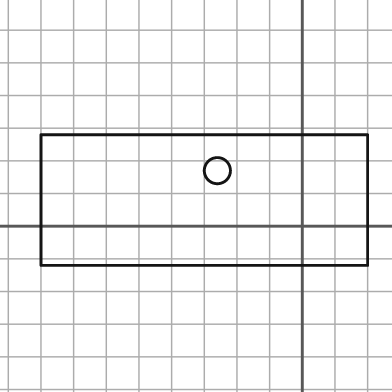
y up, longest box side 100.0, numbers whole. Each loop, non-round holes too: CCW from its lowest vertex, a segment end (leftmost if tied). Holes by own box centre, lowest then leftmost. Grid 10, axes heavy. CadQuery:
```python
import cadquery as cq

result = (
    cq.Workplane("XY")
    .moveTo(-80.0, -12.0)
    .lineTo(20.0, -12.0)
    .lineTo(20.0, 28.0)
    .lineTo(-80.0, 28.0)
    .close()
    .moveTo(-26.0, 17.0)
    .circle(4.0)
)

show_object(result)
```